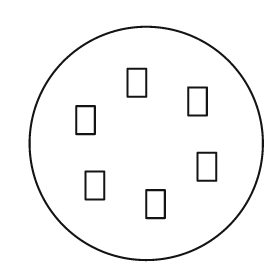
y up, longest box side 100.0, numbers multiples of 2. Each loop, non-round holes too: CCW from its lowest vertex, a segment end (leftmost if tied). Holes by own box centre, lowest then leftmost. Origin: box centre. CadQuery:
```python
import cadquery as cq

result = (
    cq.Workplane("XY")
    .moveTo(0.0, 0.0)
    .circle(50.0)
    .moveTo(0.0, -32.0)
    .lineTo(8.0, -32.0)
    .lineTo(8.0, -20.0)
    .lineTo(0.0, -20.0)
    .close()
    .moveTo(-26.0, -24.0)
    .lineTo(-18.0, -24.0)
    .lineTo(-18.0, -12.0)
    .lineTo(-26.0, -12.0)
    .close()
    .moveTo(22.0, -16.0)
    .lineTo(30.0, -16.0)
    .lineTo(30.0, -4.0)
    .lineTo(22.0, -4.0)
    .close()
    .moveTo(-30.0, 4.0)
    .lineTo(-22.0, 4.0)
    .lineTo(-22.0, 16.0)
    .lineTo(-30.0, 16.0)
    .close()
    .moveTo(18.0, 12.0)
    .lineTo(26.0, 12.0)
    .lineTo(26.0, 24.0)
    .lineTo(18.0, 24.0)
    .close()
    .moveTo(-8.0, 20.0)
    .lineTo(0.0, 20.0)
    .lineTo(0.0, 32.0)
    .lineTo(-8.0, 32.0)
    .close()
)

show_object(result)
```